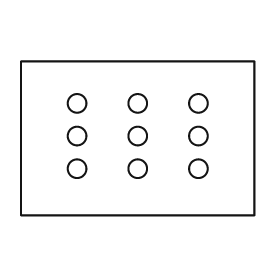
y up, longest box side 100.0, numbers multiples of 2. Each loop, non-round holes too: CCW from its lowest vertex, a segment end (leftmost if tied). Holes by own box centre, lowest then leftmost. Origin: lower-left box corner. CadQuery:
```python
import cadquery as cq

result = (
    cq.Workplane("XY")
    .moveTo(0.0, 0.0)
    .lineTo(100.0, 0.0)
    .lineTo(100.0, 66.0)
    .lineTo(0.0, 66.0)
    .close()
    .moveTo(24.0, 20.0)
    .circle(4.0)
    .moveTo(50.0, 20.0)
    .circle(4.0)
    .moveTo(76.0, 20.0)
    .circle(4.0)
    .moveTo(24.0, 34.0)
    .circle(4.0)
    .moveTo(50.0, 34.0)
    .circle(4.0)
    .moveTo(76.0, 34.0)
    .circle(4.0)
    .moveTo(24.0, 48.0)
    .circle(4.0)
    .moveTo(50.0, 48.0)
    .circle(4.0)
    .moveTo(76.0, 48.0)
    .circle(4.0)
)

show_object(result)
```